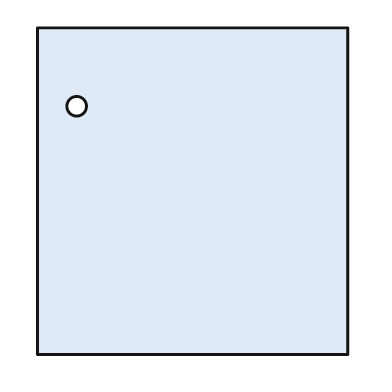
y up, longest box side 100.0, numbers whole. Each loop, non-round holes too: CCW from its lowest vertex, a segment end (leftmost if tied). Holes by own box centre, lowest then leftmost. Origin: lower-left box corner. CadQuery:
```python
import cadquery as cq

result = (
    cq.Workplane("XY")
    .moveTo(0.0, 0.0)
    .lineTo(95.0, 0.0)
    .lineTo(95.0, 100.0)
    .lineTo(0.0, 100.0)
    .close()
    .moveTo(12.0, 76.0)
    .circle(3.0)
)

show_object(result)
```